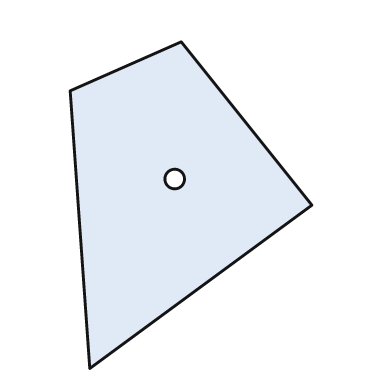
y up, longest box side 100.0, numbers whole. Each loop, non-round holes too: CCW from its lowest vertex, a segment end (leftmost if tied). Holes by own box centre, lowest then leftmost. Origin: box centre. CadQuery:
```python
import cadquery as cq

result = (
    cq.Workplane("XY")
    .moveTo(-31.0, -50.0)
    .lineTo(37.0, 0.0)
    .lineTo(-3.0, 50.0)
    .lineTo(-37.0, 35.0)
    .close()
    .moveTo(-5.0, 8.0)
    .circle(3.0)
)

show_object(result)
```